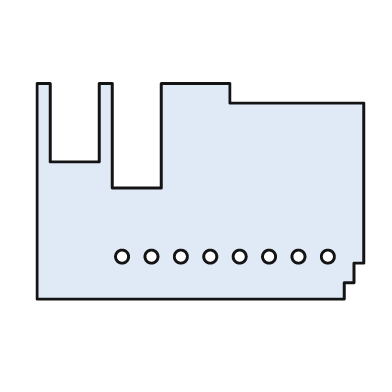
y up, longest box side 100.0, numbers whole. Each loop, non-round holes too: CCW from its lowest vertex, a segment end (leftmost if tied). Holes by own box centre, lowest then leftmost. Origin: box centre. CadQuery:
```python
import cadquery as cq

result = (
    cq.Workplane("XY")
    .moveTo(-50.0, -33.0)
    .lineTo(44.0, -33.0)
    .lineTo(44.0, -28.0)
    .lineTo(47.0, -28.0)
    .lineTo(47.0, -22.0)
    .lineTo(50.0, -22.0)
    .lineTo(50.0, 27.0)
    .lineTo(9.0, 27.0)
    .lineTo(9.0, 33.0)
    .lineTo(-12.0, 33.0)
    .lineTo(-12.0, 1.0)
    .lineTo(-27.0, 1.0)
    .lineTo(-27.0, 33.0)
    .lineTo(-31.0, 33.0)
    .lineTo(-31.0, 9.0)
    .lineTo(-46.0, 9.0)
    .lineTo(-46.0, 33.0)
    .lineTo(-50.0, 33.0)
    .close()
    .moveTo(-24.0, -20.0)
    .circle(2.0)
    .moveTo(-15.0, -20.0)
    .circle(2.0)
    .moveTo(-6.0, -20.0)
    .circle(2.0)
    .moveTo(3.0, -20.0)
    .circle(2.0)
    .moveTo(12.0, -20.0)
    .circle(2.0)
    .moveTo(21.0, -20.0)
    .circle(2.0)
    .moveTo(30.0, -20.0)
    .circle(2.0)
    .moveTo(39.0, -20.0)
    .circle(2.0)
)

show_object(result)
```